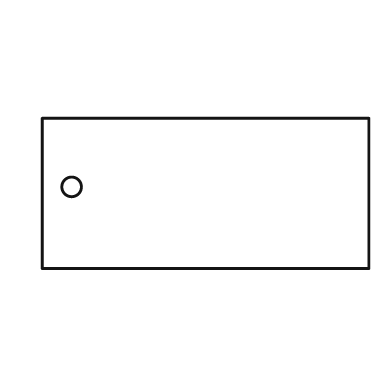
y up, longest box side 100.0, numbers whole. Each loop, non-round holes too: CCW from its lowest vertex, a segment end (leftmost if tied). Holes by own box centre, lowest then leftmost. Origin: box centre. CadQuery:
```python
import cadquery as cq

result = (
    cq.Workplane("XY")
    .moveTo(-50.0, -23.0)
    .lineTo(50.0, -23.0)
    .lineTo(50.0, 23.0)
    .lineTo(-50.0, 23.0)
    .close()
    .moveTo(-41.0, 2.0)
    .circle(3.0)
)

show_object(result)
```